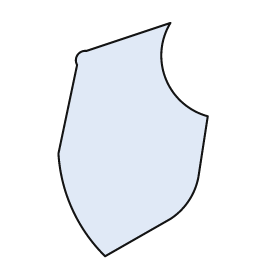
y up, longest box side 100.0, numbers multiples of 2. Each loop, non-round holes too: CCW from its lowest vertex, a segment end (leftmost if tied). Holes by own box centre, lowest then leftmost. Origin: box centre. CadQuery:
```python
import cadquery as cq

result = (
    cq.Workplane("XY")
    .moveTo(-12.0, -50.0)
    .lineTo(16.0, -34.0)
    .threePointArc((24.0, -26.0), (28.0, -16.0))
    .lineTo(32.0, 10.0)
    .threePointArc((14.0, 26.0), (16.0, 50.0))
    .lineTo(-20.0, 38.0)
    .threePointArc((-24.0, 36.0), (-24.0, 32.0))
    .lineTo(-32.0, -6.0)
    .threePointArc((-26.0, -30.0), (-12.0, -50.0))
    .close()
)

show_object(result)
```